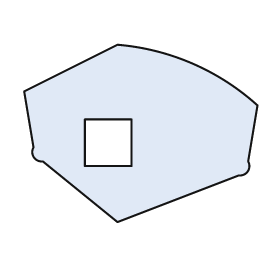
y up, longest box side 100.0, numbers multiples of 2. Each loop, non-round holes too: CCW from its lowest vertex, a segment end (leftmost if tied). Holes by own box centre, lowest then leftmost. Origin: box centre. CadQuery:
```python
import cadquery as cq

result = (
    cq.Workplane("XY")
    .moveTo(-10.0, -38.0)
    .lineTo(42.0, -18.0)
    .threePointArc((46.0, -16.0), (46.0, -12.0))
    .lineTo(50.0, 12.0)
    .threePointArc((22.0, 30.0), (-10.0, 38.0))
    .lineTo(-50.0, 18.0)
    .lineTo(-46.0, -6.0)
    .threePointArc((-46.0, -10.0), (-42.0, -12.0))
    .close()
    .moveTo(-24.0, -14.0)
    .lineTo(-4.0, -14.0)
    .lineTo(-4.0, 6.0)
    .lineTo(-24.0, 6.0)
    .close()
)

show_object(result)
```